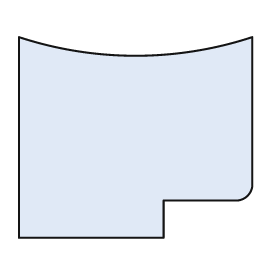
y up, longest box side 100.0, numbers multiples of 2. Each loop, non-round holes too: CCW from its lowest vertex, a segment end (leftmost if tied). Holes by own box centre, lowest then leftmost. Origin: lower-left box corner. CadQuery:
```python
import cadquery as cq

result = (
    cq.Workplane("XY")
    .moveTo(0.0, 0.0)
    .lineTo(62.0, 0.0)
    .lineTo(62.0, 16.0)
    .lineTo(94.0, 16.0)
    .threePointArc((98.0, 18.0), (100.0, 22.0))
    .lineTo(100.0, 86.0)
    .threePointArc((50.0, 78.0), (0.0, 86.0))
    .close()
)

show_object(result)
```